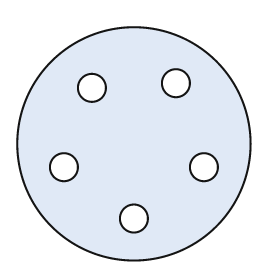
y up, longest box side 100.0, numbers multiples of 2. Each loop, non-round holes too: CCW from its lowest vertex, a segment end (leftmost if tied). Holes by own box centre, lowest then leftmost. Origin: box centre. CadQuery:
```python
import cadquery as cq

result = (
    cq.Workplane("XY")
    .moveTo(0.0, 0.0)
    .circle(50.0)
    .moveTo(0.0, -32.0)
    .circle(6.0)
    .moveTo(-30.0, -10.0)
    .circle(6.0)
    .moveTo(30.0, -10.0)
    .circle(6.0)
    .moveTo(-18.0, 24.0)
    .circle(6.0)
    .moveTo(18.0, 26.0)
    .circle(6.0)
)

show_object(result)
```